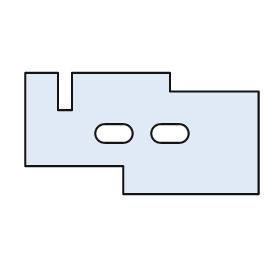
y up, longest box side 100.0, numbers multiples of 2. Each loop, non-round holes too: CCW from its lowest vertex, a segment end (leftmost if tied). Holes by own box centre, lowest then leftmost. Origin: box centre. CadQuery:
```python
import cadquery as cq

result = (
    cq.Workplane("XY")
    .moveTo(-8.0, -26.0)
    .lineTo(50.0, -26.0)
    .lineTo(50.0, 18.0)
    .lineTo(12.0, 18.0)
    .lineTo(12.0, 26.0)
    .lineTo(-30.0, 26.0)
    .lineTo(-30.0, 10.0)
    .lineTo(-36.0, 10.0)
    .lineTo(-36.0, 26.0)
    .lineTo(-50.0, 26.0)
    .lineTo(-50.0, -14.0)
    .lineTo(-8.0, -14.0)
    .close()
    .moveTo(-16.0, -4.0)
    .lineTo(-8.0, -4.0)
    .threePointArc((-4.0, 0.0), (-8.0, 4.0))
    .lineTo(-16.0, 4.0)
    .threePointArc((-20.0, 0.0), (-16.0, -4.0))
    .close()
    .moveTo(8.0, -4.0)
    .lineTo(16.0, -4.0)
    .threePointArc((20.0, 0.0), (16.0, 4.0))
    .lineTo(8.0, 4.0)
    .threePointArc((4.0, 0.0), (8.0, -4.0))
    .close()
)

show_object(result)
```